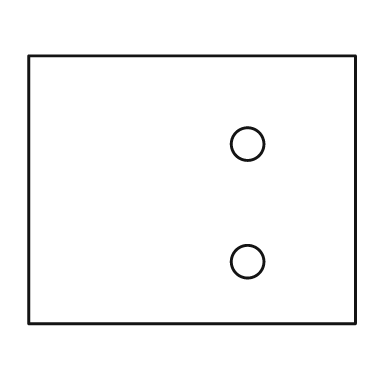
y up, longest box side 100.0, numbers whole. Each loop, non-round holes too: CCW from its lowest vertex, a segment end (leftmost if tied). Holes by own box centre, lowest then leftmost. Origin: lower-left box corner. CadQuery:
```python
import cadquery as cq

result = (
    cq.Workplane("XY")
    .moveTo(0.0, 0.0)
    .lineTo(100.0, 0.0)
    .lineTo(100.0, 82.0)
    .lineTo(0.0, 82.0)
    .close()
    .moveTo(67.0, 19.0)
    .circle(5.0)
    .moveTo(67.0, 55.0)
    .circle(5.0)
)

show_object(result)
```